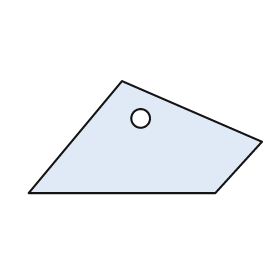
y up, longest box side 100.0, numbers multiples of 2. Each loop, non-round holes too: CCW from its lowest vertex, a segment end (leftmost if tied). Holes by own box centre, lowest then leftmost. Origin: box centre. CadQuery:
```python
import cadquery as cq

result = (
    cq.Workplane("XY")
    .moveTo(-50.0, -24.0)
    .lineTo(30.0, -24.0)
    .lineTo(50.0, -2.0)
    .lineTo(-10.0, 24.0)
    .close()
    .moveTo(-2.0, 8.0)
    .circle(4.0)
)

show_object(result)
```